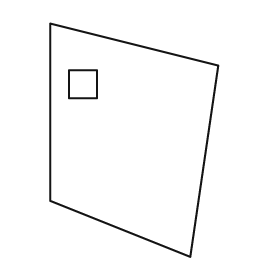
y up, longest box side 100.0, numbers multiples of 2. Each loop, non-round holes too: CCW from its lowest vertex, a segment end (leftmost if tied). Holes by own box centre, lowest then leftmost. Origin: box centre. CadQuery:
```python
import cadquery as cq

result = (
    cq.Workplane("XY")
    .moveTo(24.0, -50.0)
    .lineTo(36.0, 32.0)
    .lineTo(-36.0, 50.0)
    .lineTo(-36.0, -26.0)
    .close()
    .moveTo(-28.0, 18.0)
    .lineTo(-16.0, 18.0)
    .lineTo(-16.0, 30.0)
    .lineTo(-28.0, 30.0)
    .close()
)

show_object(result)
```